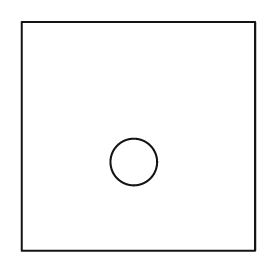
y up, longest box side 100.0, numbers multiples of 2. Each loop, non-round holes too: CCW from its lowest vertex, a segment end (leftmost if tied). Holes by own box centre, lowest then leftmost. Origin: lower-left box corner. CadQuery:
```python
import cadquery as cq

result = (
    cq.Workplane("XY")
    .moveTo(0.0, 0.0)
    .lineTo(100.0, 0.0)
    .lineTo(100.0, 98.0)
    .lineTo(0.0, 98.0)
    .close()
    .moveTo(48.0, 38.0)
    .circle(10.0)
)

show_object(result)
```